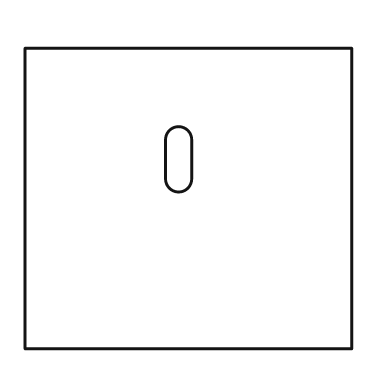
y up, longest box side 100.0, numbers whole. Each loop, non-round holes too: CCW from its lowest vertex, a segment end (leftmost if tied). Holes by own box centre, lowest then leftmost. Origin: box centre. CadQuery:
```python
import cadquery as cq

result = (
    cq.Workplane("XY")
    .moveTo(-50.0, -46.0)
    .lineTo(50.0, -46.0)
    .lineTo(50.0, 46.0)
    .lineTo(-50.0, 46.0)
    .close()
    .moveTo(-7.0, 6.0)
    .threePointArc((-3.0, 2.0), (1.0, 6.0))
    .lineTo(1.0, 18.0)
    .threePointArc((-3.0, 22.0), (-7.0, 18.0))
    .close()
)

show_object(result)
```